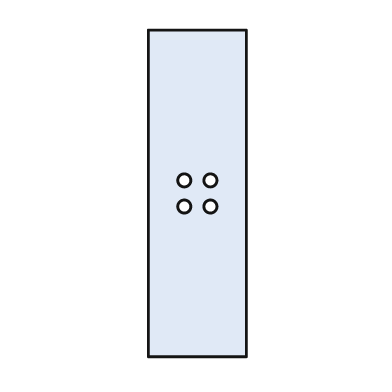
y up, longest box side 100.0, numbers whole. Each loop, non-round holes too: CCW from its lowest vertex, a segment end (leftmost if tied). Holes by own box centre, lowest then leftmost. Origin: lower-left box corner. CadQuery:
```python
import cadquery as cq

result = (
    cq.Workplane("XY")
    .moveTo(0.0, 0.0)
    .lineTo(30.0, 0.0)
    .lineTo(30.0, 100.0)
    .lineTo(0.0, 100.0)
    .close()
    .moveTo(11.0, 46.0)
    .circle(2.0)
    .moveTo(19.0, 46.0)
    .circle(2.0)
    .moveTo(11.0, 54.0)
    .circle(2.0)
    .moveTo(19.0, 54.0)
    .circle(2.0)
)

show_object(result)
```